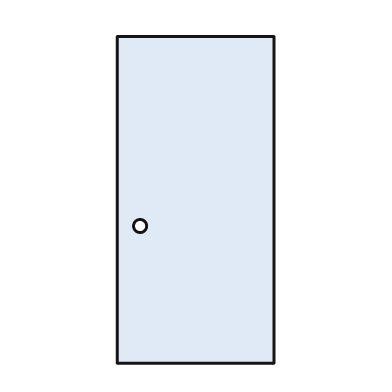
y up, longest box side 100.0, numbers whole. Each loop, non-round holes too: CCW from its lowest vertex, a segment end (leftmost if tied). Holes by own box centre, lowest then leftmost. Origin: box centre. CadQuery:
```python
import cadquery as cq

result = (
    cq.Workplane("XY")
    .moveTo(-24.0, -50.0)
    .lineTo(24.0, -50.0)
    .lineTo(24.0, 50.0)
    .lineTo(-24.0, 50.0)
    .close()
    .moveTo(-17.0, -8.0)
    .circle(2.0)
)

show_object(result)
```